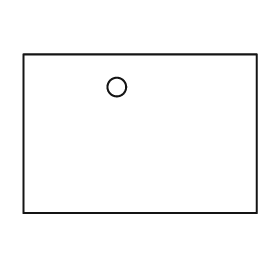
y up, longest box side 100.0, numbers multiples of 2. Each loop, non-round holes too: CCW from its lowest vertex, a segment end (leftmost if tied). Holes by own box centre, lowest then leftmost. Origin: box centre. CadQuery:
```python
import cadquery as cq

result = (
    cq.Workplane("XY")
    .moveTo(-50.0, -34.0)
    .lineTo(50.0, -34.0)
    .lineTo(50.0, 34.0)
    .lineTo(-50.0, 34.0)
    .close()
    .moveTo(-10.0, 20.0)
    .circle(4.0)
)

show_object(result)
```